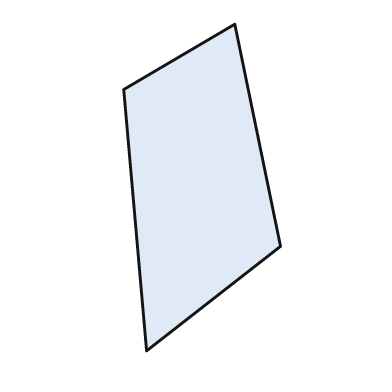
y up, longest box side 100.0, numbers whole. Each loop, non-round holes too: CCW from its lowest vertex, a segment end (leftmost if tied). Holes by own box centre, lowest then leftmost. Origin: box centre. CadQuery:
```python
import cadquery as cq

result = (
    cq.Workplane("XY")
    .moveTo(-17.0, -50.0)
    .lineTo(24.0, -18.0)
    .lineTo(10.0, 50.0)
    .lineTo(-24.0, 30.0)
    .close()
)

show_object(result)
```